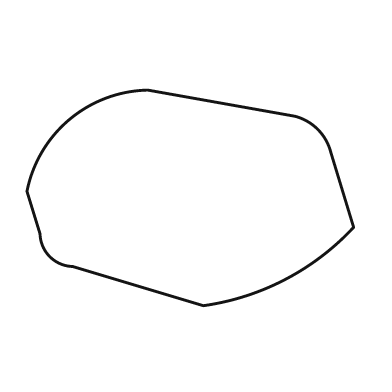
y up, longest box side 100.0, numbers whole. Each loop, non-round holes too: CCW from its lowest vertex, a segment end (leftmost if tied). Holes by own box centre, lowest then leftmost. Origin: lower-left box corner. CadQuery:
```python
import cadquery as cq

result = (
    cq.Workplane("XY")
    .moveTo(54.0, 0.0)
    .threePointArc((79.0, 8.0), (100.0, 24.0))
    .lineTo(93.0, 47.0)
    .threePointArc((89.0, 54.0), (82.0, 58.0))
    .lineTo(37.0, 66.0)
    .threePointArc((13.0, 57.0), (0.0, 35.0))
    .lineTo(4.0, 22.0)
    .threePointArc((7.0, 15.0), (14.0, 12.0))
    .close()
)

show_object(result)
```